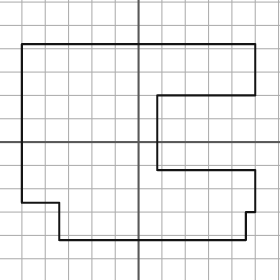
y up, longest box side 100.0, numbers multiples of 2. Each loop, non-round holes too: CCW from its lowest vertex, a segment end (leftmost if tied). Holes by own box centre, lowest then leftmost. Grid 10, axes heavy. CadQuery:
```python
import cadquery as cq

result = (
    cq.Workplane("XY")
    .moveTo(-34.0, -42.0)
    .lineTo(46.0, -42.0)
    .lineTo(46.0, -30.0)
    .lineTo(50.0, -30.0)
    .lineTo(50.0, -12.0)
    .lineTo(8.0, -12.0)
    .lineTo(8.0, 20.0)
    .lineTo(50.0, 20.0)
    .lineTo(50.0, 42.0)
    .lineTo(-50.0, 42.0)
    .lineTo(-50.0, -26.0)
    .lineTo(-34.0, -26.0)
    .close()
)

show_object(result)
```